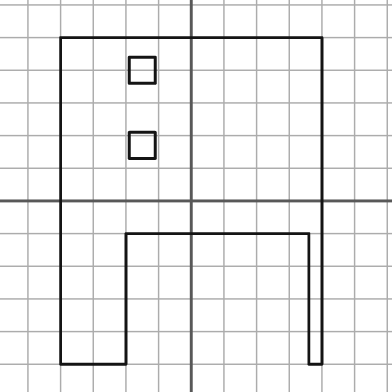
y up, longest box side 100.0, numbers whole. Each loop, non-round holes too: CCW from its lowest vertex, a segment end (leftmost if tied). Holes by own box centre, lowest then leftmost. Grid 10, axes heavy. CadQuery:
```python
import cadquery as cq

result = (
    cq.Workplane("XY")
    .moveTo(-40.0, -50.0)
    .lineTo(-20.0, -50.0)
    .lineTo(-20.0, -10.0)
    .lineTo(36.0, -10.0)
    .lineTo(36.0, -50.0)
    .lineTo(40.0, -50.0)
    .lineTo(40.0, 50.0)
    .lineTo(-40.0, 50.0)
    .close()
    .moveTo(-19.0, 13.0)
    .lineTo(-11.0, 13.0)
    .lineTo(-11.0, 21.0)
    .lineTo(-19.0, 21.0)
    .close()
    .moveTo(-19.0, 36.0)
    .lineTo(-11.0, 36.0)
    .lineTo(-11.0, 44.0)
    .lineTo(-19.0, 44.0)
    .close()
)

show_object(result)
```